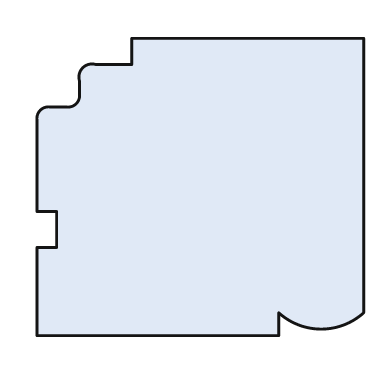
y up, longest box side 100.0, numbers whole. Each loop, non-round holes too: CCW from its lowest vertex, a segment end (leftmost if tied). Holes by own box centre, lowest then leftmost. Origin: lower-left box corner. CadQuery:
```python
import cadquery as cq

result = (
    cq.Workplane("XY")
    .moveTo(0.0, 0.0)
    .lineTo(74.0, 0.0)
    .lineTo(74.0, 7.0)
    .threePointArc((87.0, 2.0), (100.0, 7.0))
    .lineTo(100.0, 91.0)
    .lineTo(29.0, 91.0)
    .lineTo(29.0, 83.0)
    .lineTo(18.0, 83.0)
    .threePointArc((14.0, 82.0), (13.0, 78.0))
    .lineTo(13.0, 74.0)
    .threePointArc((12.0, 71.0), (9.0, 70.0))
    .lineTo(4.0, 70.0)
    .threePointArc((1.0, 69.0), (0.0, 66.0))
    .lineTo(0.0, 38.0)
    .lineTo(6.0, 38.0)
    .lineTo(6.0, 27.0)
    .lineTo(0.0, 27.0)
    .close()
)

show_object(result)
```